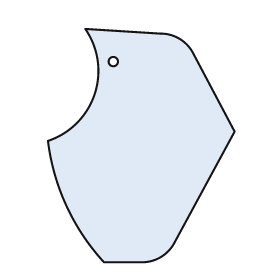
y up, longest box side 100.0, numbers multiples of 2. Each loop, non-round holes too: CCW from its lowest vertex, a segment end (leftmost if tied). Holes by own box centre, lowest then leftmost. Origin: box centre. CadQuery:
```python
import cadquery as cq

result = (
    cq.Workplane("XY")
    .moveTo(-16.0, -50.0)
    .lineTo(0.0, -50.0)
    .threePointArc((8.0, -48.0), (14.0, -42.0))
    .lineTo(40.0, 6.0)
    .lineTo(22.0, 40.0)
    .threePointArc((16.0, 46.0), (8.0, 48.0))
    .lineTo(-24.0, 50.0)
    .threePointArc((-20.0, 22.0), (-40.0, 2.0))
    .threePointArc((-32.0, -26.0), (-16.0, -50.0))
    .close()
    .moveTo(-12.0, 36.0)
    .circle(2.0)
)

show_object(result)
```